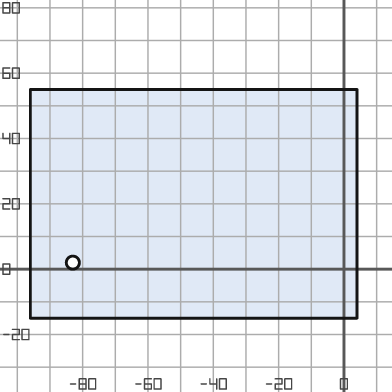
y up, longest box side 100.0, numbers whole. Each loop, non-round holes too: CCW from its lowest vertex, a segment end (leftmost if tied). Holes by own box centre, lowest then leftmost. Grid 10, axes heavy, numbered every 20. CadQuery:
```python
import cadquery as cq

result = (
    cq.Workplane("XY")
    .moveTo(-96.0, -15.0)
    .lineTo(4.0, -15.0)
    .lineTo(4.0, 55.0)
    .lineTo(-96.0, 55.0)
    .close()
    .moveTo(-83.0, 2.0)
    .circle(2.0)
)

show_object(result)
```